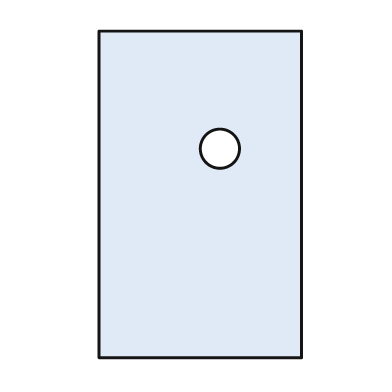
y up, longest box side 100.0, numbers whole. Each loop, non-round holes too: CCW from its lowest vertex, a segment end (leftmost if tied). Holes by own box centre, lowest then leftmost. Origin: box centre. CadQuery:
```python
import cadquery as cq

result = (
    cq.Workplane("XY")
    .moveTo(-31.0, -50.0)
    .lineTo(31.0, -50.0)
    .lineTo(31.0, 50.0)
    .lineTo(-31.0, 50.0)
    .close()
    .moveTo(6.0, 14.0)
    .circle(6.0)
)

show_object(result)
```